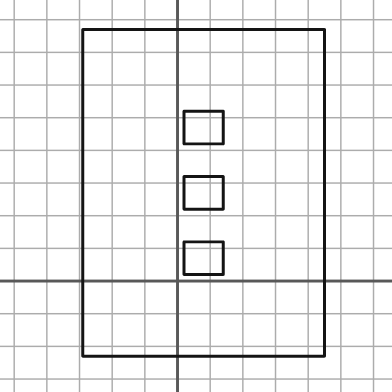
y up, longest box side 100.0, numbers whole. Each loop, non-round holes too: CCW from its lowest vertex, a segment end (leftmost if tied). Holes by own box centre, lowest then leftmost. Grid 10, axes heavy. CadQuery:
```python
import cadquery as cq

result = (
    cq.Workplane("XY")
    .moveTo(-29.0, -23.0)
    .lineTo(45.0, -23.0)
    .lineTo(45.0, 77.0)
    .lineTo(-29.0, 77.0)
    .close()
    .moveTo(2.0, 2.0)
    .lineTo(14.0, 2.0)
    .lineTo(14.0, 12.0)
    .lineTo(2.0, 12.0)
    .close()
    .moveTo(2.0, 22.0)
    .lineTo(14.0, 22.0)
    .lineTo(14.0, 32.0)
    .lineTo(2.0, 32.0)
    .close()
    .moveTo(2.0, 42.0)
    .lineTo(14.0, 42.0)
    .lineTo(14.0, 52.0)
    .lineTo(2.0, 52.0)
    .close()
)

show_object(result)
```